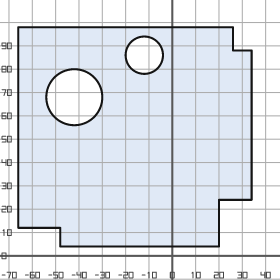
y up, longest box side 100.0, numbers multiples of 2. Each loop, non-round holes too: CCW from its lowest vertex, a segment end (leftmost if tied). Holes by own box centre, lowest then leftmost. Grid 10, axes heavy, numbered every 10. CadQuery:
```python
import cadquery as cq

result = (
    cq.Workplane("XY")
    .moveTo(-48.0, 4.0)
    .lineTo(20.0, 4.0)
    .lineTo(20.0, 24.0)
    .lineTo(34.0, 24.0)
    .lineTo(34.0, 88.0)
    .lineTo(26.0, 88.0)
    .lineTo(26.0, 98.0)
    .lineTo(-66.0, 98.0)
    .lineTo(-66.0, 12.0)
    .lineTo(-48.0, 12.0)
    .close()
    .moveTo(-42.0, 68.0)
    .circle(12.0)
    .moveTo(-12.0, 86.0)
    .circle(8.0)
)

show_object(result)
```